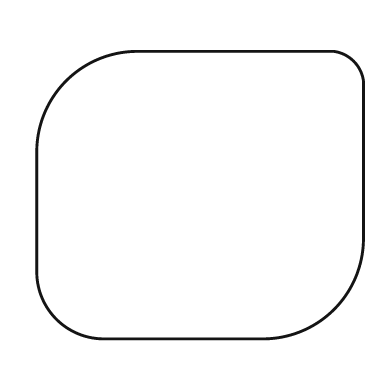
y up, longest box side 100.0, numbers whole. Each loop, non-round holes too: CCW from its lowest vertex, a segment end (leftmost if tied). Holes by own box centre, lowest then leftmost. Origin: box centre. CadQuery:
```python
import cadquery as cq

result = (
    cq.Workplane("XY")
    .moveTo(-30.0, -44.0)
    .lineTo(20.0, -44.0)
    .threePointArc((41.0, -35.0), (50.0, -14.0))
    .lineTo(50.0, 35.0)
    .threePointArc((47.0, 41.0), (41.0, 44.0))
    .lineTo(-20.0, 44.0)
    .threePointArc((-41.0, 35.0), (-50.0, 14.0))
    .lineTo(-50.0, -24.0)
    .threePointArc((-44.0, -38.0), (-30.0, -44.0))
    .close()
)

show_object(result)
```